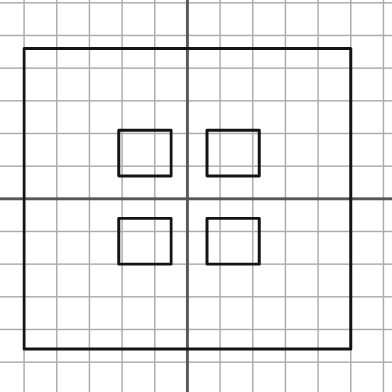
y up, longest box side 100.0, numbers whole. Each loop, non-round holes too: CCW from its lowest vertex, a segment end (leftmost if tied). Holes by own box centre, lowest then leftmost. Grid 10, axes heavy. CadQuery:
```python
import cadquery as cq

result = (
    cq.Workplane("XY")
    .moveTo(-50.0, -46.0)
    .lineTo(50.0, -46.0)
    .lineTo(50.0, 46.0)
    .lineTo(-50.0, 46.0)
    .close()
    .moveTo(-21.0, -20.0)
    .lineTo(-5.0, -20.0)
    .lineTo(-5.0, -6.0)
    .lineTo(-21.0, -6.0)
    .close()
    .moveTo(6.0, -20.0)
    .lineTo(22.0, -20.0)
    .lineTo(22.0, -6.0)
    .lineTo(6.0, -6.0)
    .close()
    .moveTo(-21.0, 7.0)
    .lineTo(-5.0, 7.0)
    .lineTo(-5.0, 21.0)
    .lineTo(-21.0, 21.0)
    .close()
    .moveTo(6.0, 7.0)
    .lineTo(22.0, 7.0)
    .lineTo(22.0, 21.0)
    .lineTo(6.0, 21.0)
    .close()
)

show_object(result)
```